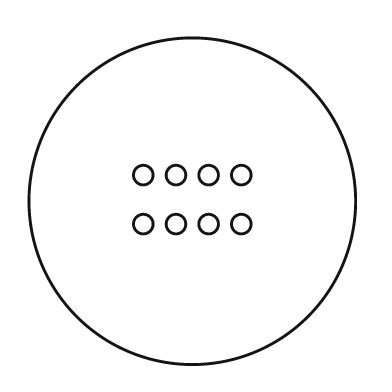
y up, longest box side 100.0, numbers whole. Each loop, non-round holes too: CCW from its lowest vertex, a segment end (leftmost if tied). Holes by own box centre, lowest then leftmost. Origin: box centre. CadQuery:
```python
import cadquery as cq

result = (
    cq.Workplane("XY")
    .moveTo(0.0, 0.0)
    .circle(50.0)
    .moveTo(-15.0, -7.0)
    .circle(3.0)
    .moveTo(-5.0, -7.0)
    .circle(3.0)
    .moveTo(5.0, -7.0)
    .circle(3.0)
    .moveTo(15.0, -7.0)
    .circle(3.0)
    .moveTo(-15.0, 8.0)
    .circle(3.0)
    .moveTo(-5.0, 8.0)
    .circle(3.0)
    .moveTo(5.0, 8.0)
    .circle(3.0)
    .moveTo(15.0, 8.0)
    .circle(3.0)
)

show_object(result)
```